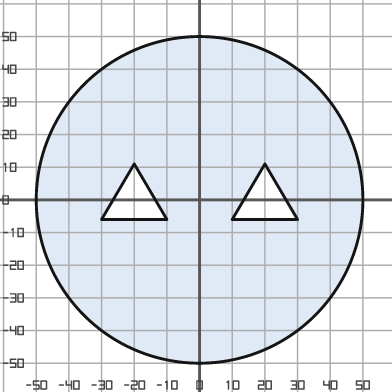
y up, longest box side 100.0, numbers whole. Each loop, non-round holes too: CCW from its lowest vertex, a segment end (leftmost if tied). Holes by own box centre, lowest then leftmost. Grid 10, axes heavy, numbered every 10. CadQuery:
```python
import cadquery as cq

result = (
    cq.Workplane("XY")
    .moveTo(0.0, 0.0)
    .circle(50.0)
    .moveTo(-30.0, -6.0)
    .lineTo(-10.0, -6.0)
    .lineTo(-20.0, 11.0)
    .close()
    .moveTo(10.0, -6.0)
    .lineTo(30.0, -6.0)
    .lineTo(20.0, 11.0)
    .close()
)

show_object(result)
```